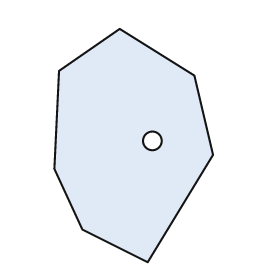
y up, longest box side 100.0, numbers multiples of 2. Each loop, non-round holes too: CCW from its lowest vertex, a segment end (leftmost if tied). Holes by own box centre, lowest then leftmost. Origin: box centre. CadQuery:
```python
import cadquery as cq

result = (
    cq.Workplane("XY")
    .moveTo(6.0, -50.0)
    .lineTo(34.0, -4.0)
    .lineTo(26.0, 30.0)
    .lineTo(-6.0, 50.0)
    .lineTo(-32.0, 32.0)
    .lineTo(-34.0, -10.0)
    .lineTo(-22.0, -36.0)
    .close()
    .moveTo(8.0, 2.0)
    .circle(4.0)
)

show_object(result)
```